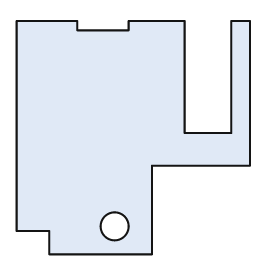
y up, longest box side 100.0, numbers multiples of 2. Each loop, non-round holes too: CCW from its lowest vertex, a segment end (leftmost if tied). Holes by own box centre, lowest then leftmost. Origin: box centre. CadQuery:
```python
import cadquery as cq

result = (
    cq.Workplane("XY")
    .moveTo(-36.0, -50.0)
    .lineTo(8.0, -50.0)
    .lineTo(8.0, -12.0)
    .lineTo(50.0, -12.0)
    .lineTo(50.0, 50.0)
    .lineTo(42.0, 50.0)
    .lineTo(42.0, 2.0)
    .lineTo(22.0, 2.0)
    .lineTo(22.0, 50.0)
    .lineTo(-2.0, 50.0)
    .lineTo(-2.0, 46.0)
    .lineTo(-24.0, 46.0)
    .lineTo(-24.0, 50.0)
    .lineTo(-50.0, 50.0)
    .lineTo(-50.0, -40.0)
    .lineTo(-36.0, -40.0)
    .close()
    .moveTo(-8.0, -38.0)
    .circle(6.0)
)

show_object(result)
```